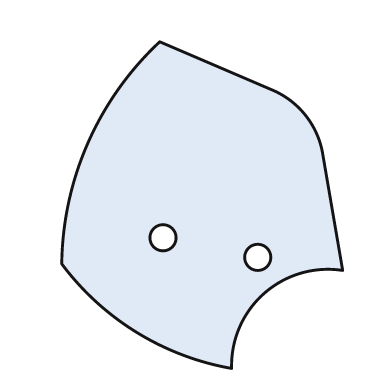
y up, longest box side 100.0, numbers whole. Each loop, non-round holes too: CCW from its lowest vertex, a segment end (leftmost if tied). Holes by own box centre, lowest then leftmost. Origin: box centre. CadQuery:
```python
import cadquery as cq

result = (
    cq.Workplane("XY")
    .moveTo(9.0, -50.0)
    .threePointArc((19.0, -27.0), (43.0, -20.0))
    .lineTo(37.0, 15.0)
    .threePointArc((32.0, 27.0), (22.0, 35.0))
    .lineTo(-13.0, 50.0)
    .threePointArc((-35.0, 19.0), (-43.0, -18.0))
    .threePointArc((-20.0, -39.0), (9.0, -50.0))
    .close()
    .moveTo(17.0, -16.0)
    .circle(4.0)
    .moveTo(-12.0, -10.0)
    .circle(4.0)
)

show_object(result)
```